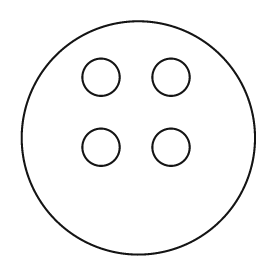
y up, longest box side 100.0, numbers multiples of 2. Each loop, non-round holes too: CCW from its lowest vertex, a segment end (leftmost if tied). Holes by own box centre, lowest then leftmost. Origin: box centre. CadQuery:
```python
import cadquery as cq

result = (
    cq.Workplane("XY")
    .moveTo(0.0, 0.0)
    .circle(50.0)
    .moveTo(-16.0, -4.0)
    .circle(8.0)
    .moveTo(14.0, -4.0)
    .circle(8.0)
    .moveTo(-16.0, 26.0)
    .circle(8.0)
    .moveTo(14.0, 26.0)
    .circle(8.0)
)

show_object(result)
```